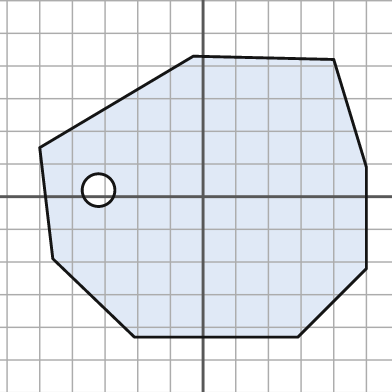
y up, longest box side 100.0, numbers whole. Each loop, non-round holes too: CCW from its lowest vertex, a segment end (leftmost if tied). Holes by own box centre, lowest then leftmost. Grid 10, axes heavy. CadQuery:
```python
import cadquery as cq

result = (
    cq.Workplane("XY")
    .moveTo(-21.0, -43.0)
    .lineTo(29.0, -43.0)
    .lineTo(50.0, -22.0)
    .lineTo(50.0, 9.0)
    .lineTo(40.0, 42.0)
    .lineTo(-3.0, 43.0)
    .lineTo(-50.0, 15.0)
    .lineTo(-46.0, -19.0)
    .close()
    .moveTo(-32.0, 2.0)
    .circle(5.0)
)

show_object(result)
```